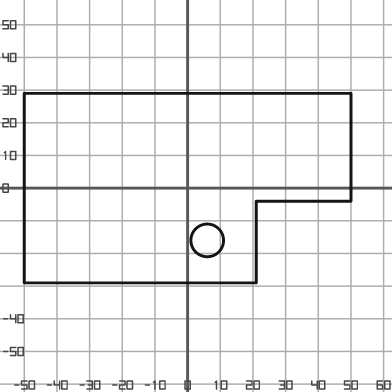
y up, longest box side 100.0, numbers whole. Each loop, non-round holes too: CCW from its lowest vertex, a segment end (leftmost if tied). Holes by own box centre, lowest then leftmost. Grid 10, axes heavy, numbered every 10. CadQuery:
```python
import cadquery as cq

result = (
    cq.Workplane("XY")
    .moveTo(-50.0, -29.0)
    .lineTo(21.0, -29.0)
    .lineTo(21.0, -4.0)
    .lineTo(50.0, -4.0)
    .lineTo(50.0, 29.0)
    .lineTo(-50.0, 29.0)
    .close()
    .moveTo(6.0, -16.0)
    .circle(5.0)
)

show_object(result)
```